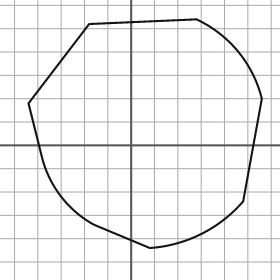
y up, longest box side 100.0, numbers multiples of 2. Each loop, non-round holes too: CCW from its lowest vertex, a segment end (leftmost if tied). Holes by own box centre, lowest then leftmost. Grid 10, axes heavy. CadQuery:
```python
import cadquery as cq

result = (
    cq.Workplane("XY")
    .moveTo(8.0, -44.0)
    .threePointArc((30.0, -38.0), (48.0, -24.0))
    .lineTo(56.0, 20.0)
    .threePointArc((46.0, 40.0), (28.0, 54.0))
    .lineTo(-18.0, 52.0)
    .lineTo(-44.0, 18.0)
    .lineTo(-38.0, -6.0)
    .threePointArc((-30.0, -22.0), (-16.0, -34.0))
    .close()
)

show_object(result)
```